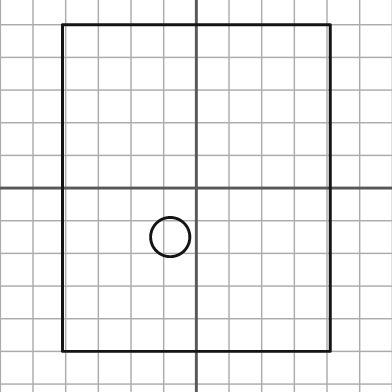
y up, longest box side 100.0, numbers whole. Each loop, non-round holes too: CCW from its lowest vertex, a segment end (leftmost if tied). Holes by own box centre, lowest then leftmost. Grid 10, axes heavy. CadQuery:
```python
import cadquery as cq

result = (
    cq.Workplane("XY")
    .moveTo(-41.0, -50.0)
    .lineTo(41.0, -50.0)
    .lineTo(41.0, 50.0)
    .lineTo(-41.0, 50.0)
    .close()
    .moveTo(-8.0, -15.0)
    .circle(6.0)
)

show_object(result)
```